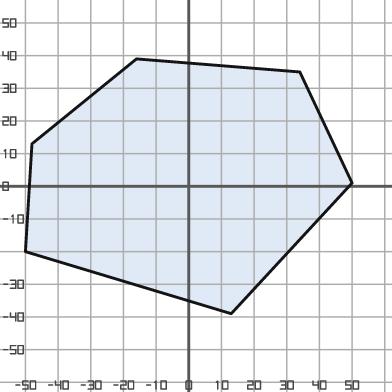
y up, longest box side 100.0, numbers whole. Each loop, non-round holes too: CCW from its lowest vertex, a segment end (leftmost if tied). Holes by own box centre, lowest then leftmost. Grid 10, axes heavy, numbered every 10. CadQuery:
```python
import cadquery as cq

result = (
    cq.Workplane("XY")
    .moveTo(13.0, -39.0)
    .lineTo(50.0, 1.0)
    .lineTo(34.0, 35.0)
    .lineTo(-16.0, 39.0)
    .lineTo(-48.0, 13.0)
    .lineTo(-50.0, -20.0)
    .close()
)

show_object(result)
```